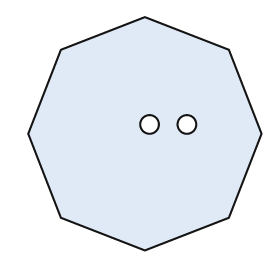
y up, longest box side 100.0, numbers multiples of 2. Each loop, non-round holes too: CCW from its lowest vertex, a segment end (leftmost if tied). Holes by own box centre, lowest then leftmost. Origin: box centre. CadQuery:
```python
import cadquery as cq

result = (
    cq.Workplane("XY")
    .moveTo(0.0, -50.0)
    .lineTo(36.0, -36.0)
    .lineTo(50.0, 0.0)
    .lineTo(36.0, 36.0)
    .lineTo(0.0, 50.0)
    .lineTo(-36.0, 36.0)
    .lineTo(-50.0, 0.0)
    .lineTo(-36.0, -36.0)
    .close()
    .moveTo(2.0, 4.0)
    .circle(4.0)
    .moveTo(18.0, 4.0)
    .circle(4.0)
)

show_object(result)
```